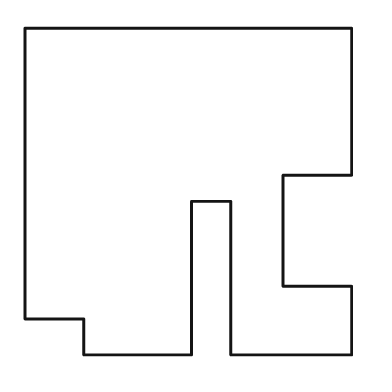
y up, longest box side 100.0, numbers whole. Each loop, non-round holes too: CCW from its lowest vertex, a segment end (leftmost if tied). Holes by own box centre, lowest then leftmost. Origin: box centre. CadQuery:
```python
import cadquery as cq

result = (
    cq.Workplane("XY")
    .moveTo(-32.0, -50.0)
    .lineTo(1.0, -50.0)
    .lineTo(1.0, -3.0)
    .lineTo(13.0, -3.0)
    .lineTo(13.0, -50.0)
    .lineTo(50.0, -50.0)
    .lineTo(50.0, -29.0)
    .lineTo(29.0, -29.0)
    .lineTo(29.0, 5.0)
    .lineTo(50.0, 5.0)
    .lineTo(50.0, 50.0)
    .lineTo(-50.0, 50.0)
    .lineTo(-50.0, -39.0)
    .lineTo(-32.0, -39.0)
    .close()
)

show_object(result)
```